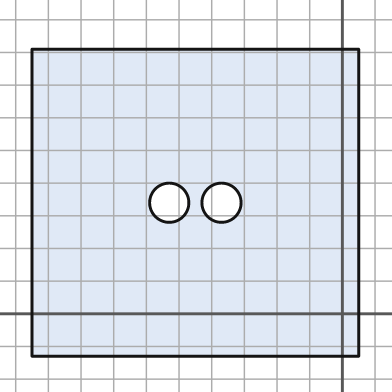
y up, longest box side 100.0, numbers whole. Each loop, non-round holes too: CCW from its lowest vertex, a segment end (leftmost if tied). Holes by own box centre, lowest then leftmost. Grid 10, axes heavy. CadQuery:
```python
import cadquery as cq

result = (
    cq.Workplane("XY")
    .moveTo(-95.0, -13.0)
    .lineTo(5.0, -13.0)
    .lineTo(5.0, 81.0)
    .lineTo(-95.0, 81.0)
    .close()
    .moveTo(-53.0, 34.0)
    .circle(6.0)
    .moveTo(-37.0, 34.0)
    .circle(6.0)
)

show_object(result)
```